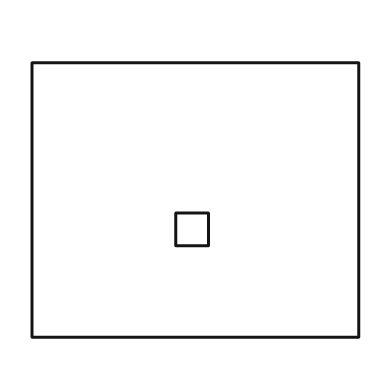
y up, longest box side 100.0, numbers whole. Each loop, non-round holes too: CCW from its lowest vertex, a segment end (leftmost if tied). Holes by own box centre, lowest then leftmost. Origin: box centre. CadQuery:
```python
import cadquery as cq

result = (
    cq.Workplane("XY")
    .moveTo(-50.0, -42.0)
    .lineTo(50.0, -42.0)
    .lineTo(50.0, 42.0)
    .lineTo(-50.0, 42.0)
    .close()
    .moveTo(-6.0, -14.0)
    .lineTo(4.0, -14.0)
    .lineTo(4.0, -4.0)
    .lineTo(-6.0, -4.0)
    .close()
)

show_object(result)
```